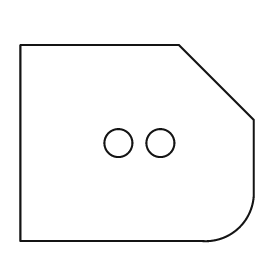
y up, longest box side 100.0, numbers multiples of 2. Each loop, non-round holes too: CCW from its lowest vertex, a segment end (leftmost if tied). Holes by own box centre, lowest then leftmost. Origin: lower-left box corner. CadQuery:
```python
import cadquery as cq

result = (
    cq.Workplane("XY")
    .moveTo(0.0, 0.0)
    .lineTo(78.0, 0.0)
    .threePointArc((94.0, 6.0), (100.0, 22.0))
    .lineTo(100.0, 52.0)
    .lineTo(68.0, 84.0)
    .lineTo(0.0, 84.0)
    .close()
    .moveTo(42.0, 42.0)
    .circle(6.0)
    .moveTo(60.0, 42.0)
    .circle(6.0)
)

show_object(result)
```